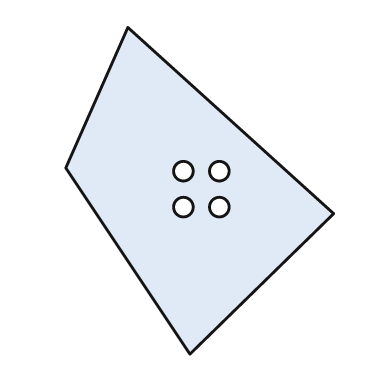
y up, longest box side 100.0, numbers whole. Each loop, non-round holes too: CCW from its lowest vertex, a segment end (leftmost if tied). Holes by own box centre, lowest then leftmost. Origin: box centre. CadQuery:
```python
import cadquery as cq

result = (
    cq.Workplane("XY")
    .moveTo(-3.0, -50.0)
    .lineTo(41.0, -7.0)
    .lineTo(-22.0, 50.0)
    .lineTo(-41.0, 7.0)
    .close()
    .moveTo(-5.0, -5.0)
    .circle(3.0)
    .moveTo(6.0, -5.0)
    .circle(3.0)
    .moveTo(-5.0, 6.0)
    .circle(3.0)
    .moveTo(6.0, 6.0)
    .circle(3.0)
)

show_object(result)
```